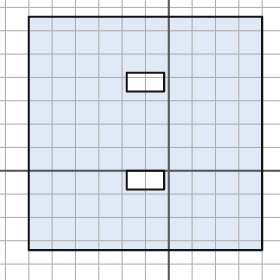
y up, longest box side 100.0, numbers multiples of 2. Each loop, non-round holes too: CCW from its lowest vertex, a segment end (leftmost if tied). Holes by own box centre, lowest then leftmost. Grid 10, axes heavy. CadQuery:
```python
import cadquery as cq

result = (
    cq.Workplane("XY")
    .moveTo(-60.0, -34.0)
    .lineTo(40.0, -34.0)
    .lineTo(40.0, 66.0)
    .lineTo(-60.0, 66.0)
    .close()
    .moveTo(-18.0, -8.0)
    .lineTo(-2.0, -8.0)
    .lineTo(-2.0, 0.0)
    .lineTo(-18.0, 0.0)
    .close()
    .moveTo(-18.0, 34.0)
    .lineTo(-2.0, 34.0)
    .lineTo(-2.0, 42.0)
    .lineTo(-18.0, 42.0)
    .close()
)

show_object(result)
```